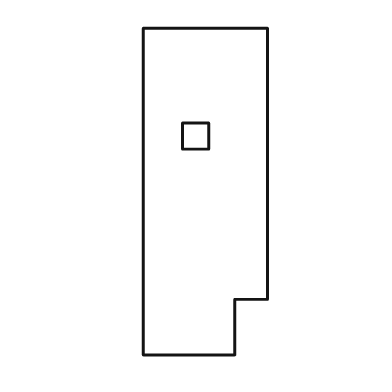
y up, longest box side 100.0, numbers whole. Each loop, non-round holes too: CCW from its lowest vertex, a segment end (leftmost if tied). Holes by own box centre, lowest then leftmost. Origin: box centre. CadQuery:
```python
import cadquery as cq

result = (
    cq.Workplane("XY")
    .moveTo(-19.0, -50.0)
    .lineTo(9.0, -50.0)
    .lineTo(9.0, -33.0)
    .lineTo(19.0, -33.0)
    .lineTo(19.0, 50.0)
    .lineTo(-19.0, 50.0)
    .close()
    .moveTo(-7.0, 13.0)
    .lineTo(1.0, 13.0)
    .lineTo(1.0, 21.0)
    .lineTo(-7.0, 21.0)
    .close()
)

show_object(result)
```